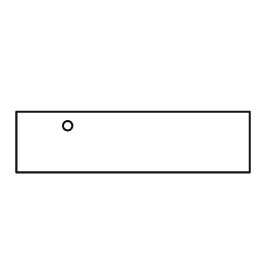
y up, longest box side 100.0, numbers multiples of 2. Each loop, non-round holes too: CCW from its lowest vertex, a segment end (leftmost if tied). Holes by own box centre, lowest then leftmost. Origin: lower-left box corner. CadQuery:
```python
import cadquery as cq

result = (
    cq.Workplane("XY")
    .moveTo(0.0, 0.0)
    .lineTo(100.0, 0.0)
    .lineTo(100.0, 26.0)
    .lineTo(0.0, 26.0)
    .close()
    .moveTo(22.0, 20.0)
    .circle(2.0)
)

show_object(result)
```